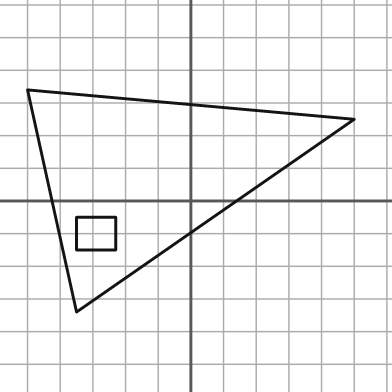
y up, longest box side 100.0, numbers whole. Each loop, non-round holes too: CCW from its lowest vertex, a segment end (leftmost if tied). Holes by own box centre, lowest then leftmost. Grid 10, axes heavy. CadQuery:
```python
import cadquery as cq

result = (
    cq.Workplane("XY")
    .moveTo(-35.0, -34.0)
    .lineTo(50.0, 25.0)
    .lineTo(-50.0, 34.0)
    .close()
    .moveTo(-35.0, -15.0)
    .lineTo(-23.0, -15.0)
    .lineTo(-23.0, -5.0)
    .lineTo(-35.0, -5.0)
    .close()
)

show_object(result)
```